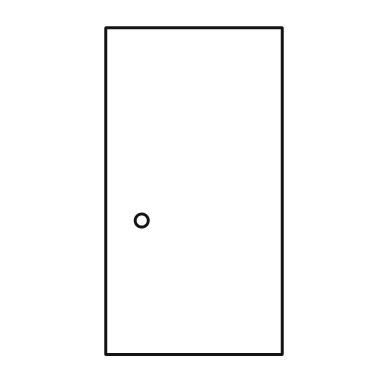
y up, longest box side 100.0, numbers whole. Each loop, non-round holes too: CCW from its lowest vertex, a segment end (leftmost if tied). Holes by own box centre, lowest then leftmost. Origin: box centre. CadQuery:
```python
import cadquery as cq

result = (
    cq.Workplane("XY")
    .moveTo(-27.0, -50.0)
    .lineTo(27.0, -50.0)
    .lineTo(27.0, 50.0)
    .lineTo(-27.0, 50.0)
    .close()
    .moveTo(-16.0, -9.0)
    .circle(2.0)
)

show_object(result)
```